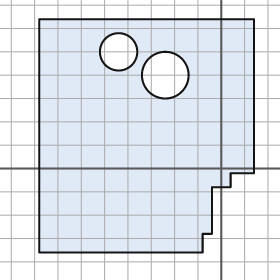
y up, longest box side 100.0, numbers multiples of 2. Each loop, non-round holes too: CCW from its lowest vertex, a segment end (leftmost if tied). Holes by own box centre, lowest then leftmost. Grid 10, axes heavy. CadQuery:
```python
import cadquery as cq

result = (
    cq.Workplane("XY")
    .moveTo(-78.0, -36.0)
    .lineTo(-8.0, -36.0)
    .lineTo(-8.0, -28.0)
    .lineTo(-4.0, -28.0)
    .lineTo(-4.0, -8.0)
    .lineTo(4.0, -8.0)
    .lineTo(4.0, -2.0)
    .lineTo(14.0, -2.0)
    .lineTo(14.0, 64.0)
    .lineTo(-78.0, 64.0)
    .close()
    .moveTo(-24.0, 40.0)
    .circle(10.0)
    .moveTo(-44.0, 50.0)
    .circle(8.0)
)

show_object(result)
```